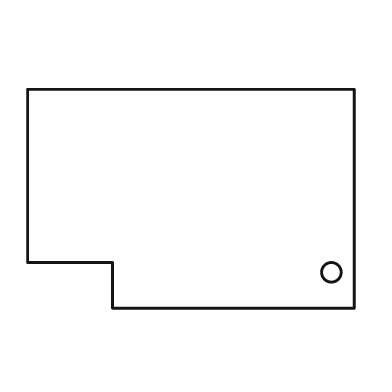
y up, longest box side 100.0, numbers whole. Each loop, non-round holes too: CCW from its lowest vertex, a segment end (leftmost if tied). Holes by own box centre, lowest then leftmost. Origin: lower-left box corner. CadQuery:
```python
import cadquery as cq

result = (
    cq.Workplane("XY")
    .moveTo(26.0, 0.0)
    .lineTo(100.0, 0.0)
    .lineTo(100.0, 67.0)
    .lineTo(0.0, 67.0)
    .lineTo(0.0, 14.0)
    .lineTo(26.0, 14.0)
    .close()
    .moveTo(93.0, 11.0)
    .circle(3.0)
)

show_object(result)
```